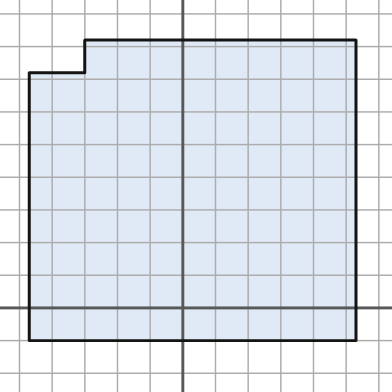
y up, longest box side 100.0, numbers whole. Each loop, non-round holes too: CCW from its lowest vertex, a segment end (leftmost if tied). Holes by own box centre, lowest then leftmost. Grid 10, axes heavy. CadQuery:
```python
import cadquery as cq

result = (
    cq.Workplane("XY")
    .moveTo(-47.0, -10.0)
    .lineTo(53.0, -10.0)
    .lineTo(53.0, 82.0)
    .lineTo(-30.0, 82.0)
    .lineTo(-30.0, 72.0)
    .lineTo(-47.0, 72.0)
    .close()
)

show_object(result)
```